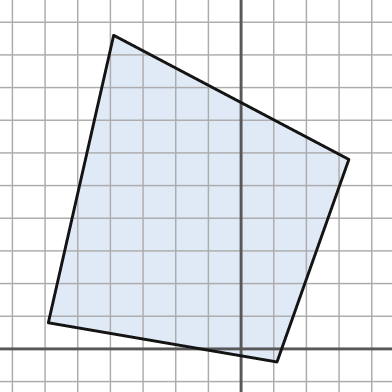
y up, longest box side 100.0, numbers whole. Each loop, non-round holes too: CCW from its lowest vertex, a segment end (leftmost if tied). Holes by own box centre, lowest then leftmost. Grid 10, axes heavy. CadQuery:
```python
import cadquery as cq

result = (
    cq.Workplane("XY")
    .moveTo(11.0, -4.0)
    .lineTo(33.0, 58.0)
    .lineTo(-39.0, 96.0)
    .lineTo(-59.0, 8.0)
    .close()
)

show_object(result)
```